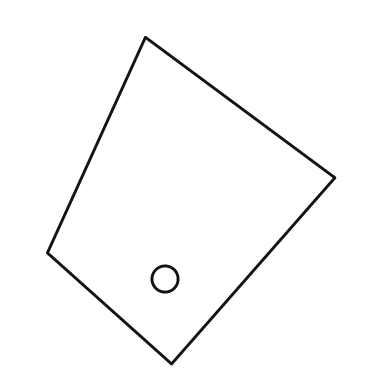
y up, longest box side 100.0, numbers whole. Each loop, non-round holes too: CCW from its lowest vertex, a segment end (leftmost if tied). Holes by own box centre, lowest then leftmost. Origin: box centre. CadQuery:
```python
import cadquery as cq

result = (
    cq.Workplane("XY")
    .moveTo(-6.0, -50.0)
    .lineTo(44.0, 7.0)
    .lineTo(-14.0, 50.0)
    .lineTo(-44.0, -16.0)
    .close()
    .moveTo(-8.0, -24.0)
    .circle(4.0)
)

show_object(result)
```